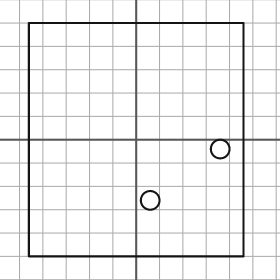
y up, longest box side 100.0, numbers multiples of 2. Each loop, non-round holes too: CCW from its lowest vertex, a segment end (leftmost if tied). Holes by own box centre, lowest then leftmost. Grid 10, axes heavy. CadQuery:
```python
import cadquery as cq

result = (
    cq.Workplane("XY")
    .moveTo(-46.0, -50.0)
    .lineTo(46.0, -50.0)
    .lineTo(46.0, 50.0)
    .lineTo(-46.0, 50.0)
    .close()
    .moveTo(6.0, -26.0)
    .circle(4.0)
    .moveTo(36.0, -4.0)
    .circle(4.0)
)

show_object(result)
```